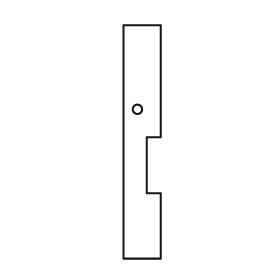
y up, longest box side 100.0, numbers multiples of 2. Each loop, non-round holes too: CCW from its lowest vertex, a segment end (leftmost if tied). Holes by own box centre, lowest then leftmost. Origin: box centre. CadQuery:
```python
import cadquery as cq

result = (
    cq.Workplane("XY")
    .moveTo(-8.0, -50.0)
    .lineTo(8.0, -50.0)
    .lineTo(8.0, -22.0)
    .lineTo(2.0, -22.0)
    .lineTo(2.0, 2.0)
    .lineTo(8.0, 2.0)
    .lineTo(8.0, 50.0)
    .lineTo(-8.0, 50.0)
    .close()
    .moveTo(-2.0, 14.0)
    .circle(2.0)
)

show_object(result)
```